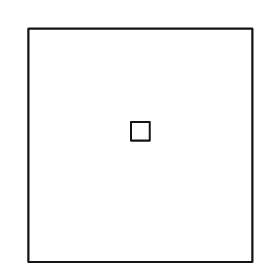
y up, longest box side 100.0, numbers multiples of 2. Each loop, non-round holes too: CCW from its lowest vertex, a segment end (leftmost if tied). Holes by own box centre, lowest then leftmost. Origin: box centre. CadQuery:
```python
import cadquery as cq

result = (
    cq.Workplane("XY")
    .moveTo(-48.0, -50.0)
    .lineTo(48.0, -50.0)
    .lineTo(48.0, 50.0)
    .lineTo(-48.0, 50.0)
    .close()
    .moveTo(-4.0, 2.0)
    .lineTo(4.0, 2.0)
    .lineTo(4.0, 10.0)
    .lineTo(-4.0, 10.0)
    .close()
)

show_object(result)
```